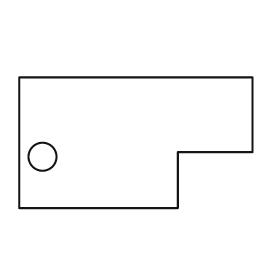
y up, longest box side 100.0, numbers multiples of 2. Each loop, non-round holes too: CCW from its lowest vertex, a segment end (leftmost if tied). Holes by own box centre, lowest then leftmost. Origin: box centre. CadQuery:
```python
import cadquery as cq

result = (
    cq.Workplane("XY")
    .moveTo(-50.0, -28.0)
    .lineTo(18.0, -28.0)
    .lineTo(18.0, -4.0)
    .lineTo(50.0, -4.0)
    .lineTo(50.0, 28.0)
    .lineTo(-50.0, 28.0)
    .close()
    .moveTo(-40.0, -6.0)
    .circle(6.0)
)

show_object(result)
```